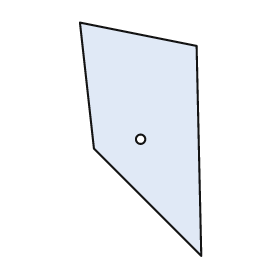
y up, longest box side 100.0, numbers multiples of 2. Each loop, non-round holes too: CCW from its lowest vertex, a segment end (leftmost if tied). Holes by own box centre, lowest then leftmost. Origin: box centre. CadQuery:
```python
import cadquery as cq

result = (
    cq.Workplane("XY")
    .moveTo(26.0, -50.0)
    .lineTo(24.0, 40.0)
    .lineTo(-26.0, 50.0)
    .lineTo(-20.0, -4.0)
    .close()
    .moveTo(0.0, 0.0)
    .circle(2.0)
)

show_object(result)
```